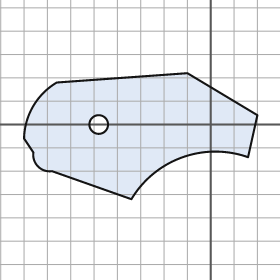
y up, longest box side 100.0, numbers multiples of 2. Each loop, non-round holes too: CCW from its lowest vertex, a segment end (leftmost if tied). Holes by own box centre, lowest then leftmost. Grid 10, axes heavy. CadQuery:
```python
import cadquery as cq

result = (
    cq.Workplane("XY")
    .moveTo(-34.0, -32.0)
    .threePointArc((-12.0, -14.0), (16.0, -14.0))
    .lineTo(20.0, 4.0)
    .lineTo(-10.0, 22.0)
    .lineTo(-66.0, 18.0)
    .threePointArc((-76.0, 8.0), (-80.0, -6.0))
    .lineTo(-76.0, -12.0)
    .threePointArc((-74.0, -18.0), (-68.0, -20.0))
    .close()
    .moveTo(-48.0, 0.0)
    .circle(4.0)
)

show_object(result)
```